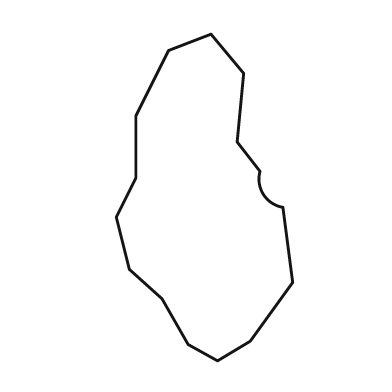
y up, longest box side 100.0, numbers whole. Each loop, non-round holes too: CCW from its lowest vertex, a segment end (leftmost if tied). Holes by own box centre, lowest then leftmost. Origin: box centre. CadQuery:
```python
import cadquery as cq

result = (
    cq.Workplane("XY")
    .moveTo(4.0, -50.0)
    .lineTo(14.0, -44.0)
    .lineTo(27.0, -26.0)
    .lineTo(24.0, -3.0)
    .threePointArc((18.0, 1.0), (17.0, 8.0))
    .lineTo(10.0, 17.0)
    .lineTo(12.0, 38.0)
    .lineTo(2.0, 50.0)
    .lineTo(-11.0, 45.0)
    .lineTo(-21.0, 25.0)
    .lineTo(-21.0, 6.0)
    .lineTo(-27.0, -6.0)
    .lineTo(-23.0, -22.0)
    .lineTo(-13.0, -31.0)
    .lineTo(-5.0, -45.0)
    .close()
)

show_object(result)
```